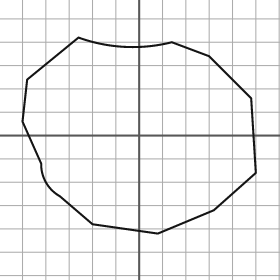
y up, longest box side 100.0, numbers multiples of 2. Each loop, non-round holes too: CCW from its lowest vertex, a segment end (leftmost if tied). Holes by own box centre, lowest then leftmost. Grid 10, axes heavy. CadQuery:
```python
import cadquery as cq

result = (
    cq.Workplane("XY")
    .moveTo(8.0, -42.0)
    .lineTo(32.0, -32.0)
    .lineTo(50.0, -16.0)
    .lineTo(48.0, 16.0)
    .lineTo(30.0, 34.0)
    .lineTo(14.0, 40.0)
    .threePointArc((-6.0, 38.0), (-26.0, 42.0))
    .lineTo(-48.0, 24.0)
    .lineTo(-50.0, 6.0)
    .lineTo(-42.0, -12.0)
    .threePointArc((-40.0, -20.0), (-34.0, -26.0))
    .lineTo(-20.0, -38.0)
    .close()
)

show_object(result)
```